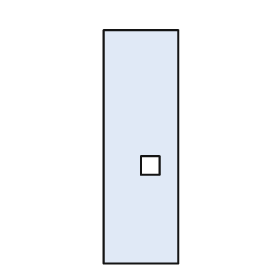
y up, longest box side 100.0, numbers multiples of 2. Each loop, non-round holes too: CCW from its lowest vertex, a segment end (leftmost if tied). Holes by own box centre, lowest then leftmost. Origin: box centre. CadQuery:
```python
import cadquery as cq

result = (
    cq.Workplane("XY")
    .moveTo(-16.0, -50.0)
    .lineTo(16.0, -50.0)
    .lineTo(16.0, 50.0)
    .lineTo(-16.0, 50.0)
    .close()
    .moveTo(0.0, -12.0)
    .lineTo(8.0, -12.0)
    .lineTo(8.0, -4.0)
    .lineTo(0.0, -4.0)
    .close()
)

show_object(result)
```